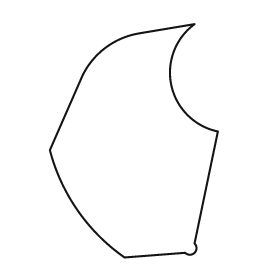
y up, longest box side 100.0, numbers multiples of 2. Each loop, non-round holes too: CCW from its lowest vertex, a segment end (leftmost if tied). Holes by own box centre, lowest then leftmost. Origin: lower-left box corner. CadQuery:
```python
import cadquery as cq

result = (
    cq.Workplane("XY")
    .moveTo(32.0, 0.0)
    .lineTo(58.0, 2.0)
    .threePointArc((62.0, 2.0), (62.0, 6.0))
    .lineTo(72.0, 54.0)
    .threePointArc((52.0, 74.0), (62.0, 100.0))
    .lineTo(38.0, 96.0)
    .threePointArc((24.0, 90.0), (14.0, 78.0))
    .lineTo(0.0, 46.0)
    .threePointArc((12.0, 20.0), (32.0, 0.0))
    .close()
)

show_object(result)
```